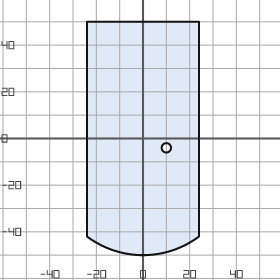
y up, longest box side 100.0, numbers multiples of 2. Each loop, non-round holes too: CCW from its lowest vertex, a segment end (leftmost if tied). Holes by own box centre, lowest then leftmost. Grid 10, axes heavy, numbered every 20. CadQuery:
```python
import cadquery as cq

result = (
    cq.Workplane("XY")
    .moveTo(-24.0, -42.0)
    .threePointArc((0.0, -50.0), (24.0, -42.0))
    .lineTo(24.0, 50.0)
    .lineTo(-24.0, 50.0)
    .close()
    .moveTo(10.0, -4.0)
    .circle(2.0)
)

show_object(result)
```